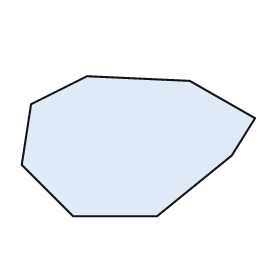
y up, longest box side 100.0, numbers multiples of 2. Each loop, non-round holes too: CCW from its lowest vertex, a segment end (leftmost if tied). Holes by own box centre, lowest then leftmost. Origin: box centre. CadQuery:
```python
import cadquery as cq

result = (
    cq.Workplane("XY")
    .moveTo(-28.0, -30.0)
    .lineTo(8.0, -30.0)
    .lineTo(40.0, -4.0)
    .lineTo(50.0, 12.0)
    .lineTo(22.0, 28.0)
    .lineTo(-22.0, 30.0)
    .lineTo(-46.0, 18.0)
    .lineTo(-50.0, -8.0)
    .close()
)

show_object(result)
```